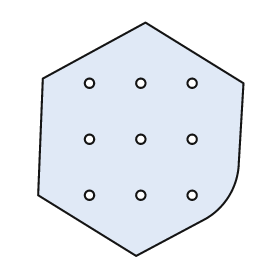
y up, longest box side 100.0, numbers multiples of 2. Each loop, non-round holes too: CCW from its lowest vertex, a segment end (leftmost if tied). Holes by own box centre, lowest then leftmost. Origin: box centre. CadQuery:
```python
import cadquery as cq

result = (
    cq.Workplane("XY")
    .moveTo(-2.0, -50.0)
    .lineTo(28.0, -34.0)
    .threePointArc((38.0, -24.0), (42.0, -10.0))
    .lineTo(44.0, 24.0)
    .lineTo(2.0, 50.0)
    .lineTo(-42.0, 26.0)
    .lineTo(-44.0, -24.0)
    .close()
    .moveTo(-22.0, -24.0)
    .circle(2.0)
    .moveTo(0.0, -24.0)
    .circle(2.0)
    .moveTo(22.0, -24.0)
    .circle(2.0)
    .moveTo(-22.0, 0.0)
    .circle(2.0)
    .moveTo(0.0, 0.0)
    .circle(2.0)
    .moveTo(22.0, 0.0)
    .circle(2.0)
    .moveTo(-22.0, 24.0)
    .circle(2.0)
    .moveTo(0.0, 24.0)
    .circle(2.0)
    .moveTo(22.0, 24.0)
    .circle(2.0)
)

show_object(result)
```